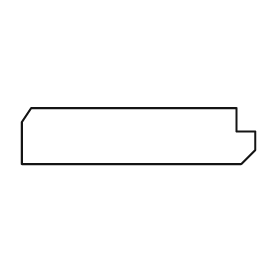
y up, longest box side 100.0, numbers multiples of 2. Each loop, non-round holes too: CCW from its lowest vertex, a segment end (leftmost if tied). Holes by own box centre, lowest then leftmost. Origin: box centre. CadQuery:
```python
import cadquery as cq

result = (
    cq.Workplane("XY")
    .moveTo(-50.0, -12.0)
    .lineTo(44.0, -12.0)
    .lineTo(50.0, -6.0)
    .lineTo(50.0, 2.0)
    .lineTo(42.0, 2.0)
    .lineTo(42.0, 12.0)
    .lineTo(-46.0, 12.0)
    .lineTo(-50.0, 6.0)
    .close()
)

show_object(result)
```